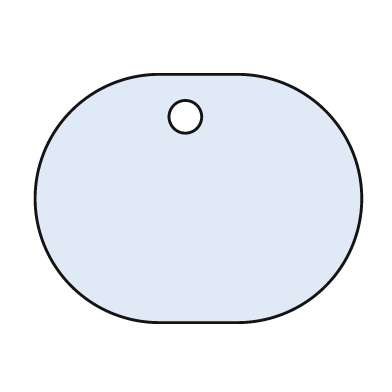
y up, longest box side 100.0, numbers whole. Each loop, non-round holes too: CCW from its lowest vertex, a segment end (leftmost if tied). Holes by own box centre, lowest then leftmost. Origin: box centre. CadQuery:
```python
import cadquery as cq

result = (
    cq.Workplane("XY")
    .moveTo(-12.0, -38.0)
    .lineTo(12.0, -38.0)
    .threePointArc((50.0, 0.0), (12.0, 38.0))
    .lineTo(-12.0, 38.0)
    .threePointArc((-50.0, 0.0), (-12.0, -38.0))
    .close()
    .moveTo(-4.0, 25.0)
    .circle(5.0)
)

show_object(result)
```